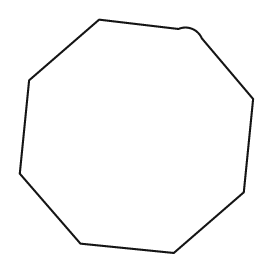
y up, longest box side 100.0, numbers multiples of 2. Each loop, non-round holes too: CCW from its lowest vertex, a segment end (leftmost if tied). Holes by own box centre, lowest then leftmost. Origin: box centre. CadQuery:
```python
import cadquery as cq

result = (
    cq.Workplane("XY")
    .moveTo(16.0, -50.0)
    .lineTo(46.0, -24.0)
    .lineTo(50.0, 16.0)
    .lineTo(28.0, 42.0)
    .threePointArc((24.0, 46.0), (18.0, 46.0))
    .lineTo(-16.0, 50.0)
    .lineTo(-46.0, 24.0)
    .lineTo(-50.0, -16.0)
    .lineTo(-24.0, -46.0)
    .close()
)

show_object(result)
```